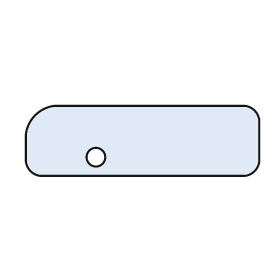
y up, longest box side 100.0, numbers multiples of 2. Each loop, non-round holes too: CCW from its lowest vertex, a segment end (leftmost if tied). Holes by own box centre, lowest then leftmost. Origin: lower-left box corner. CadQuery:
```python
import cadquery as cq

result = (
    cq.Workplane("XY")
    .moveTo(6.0, 0.0)
    .lineTo(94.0, 0.0)
    .threePointArc((98.0, 2.0), (100.0, 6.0))
    .lineTo(100.0, 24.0)
    .threePointArc((98.0, 28.0), (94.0, 30.0))
    .lineTo(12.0, 30.0)
    .threePointArc((4.0, 26.0), (0.0, 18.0))
    .lineTo(0.0, 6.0)
    .threePointArc((2.0, 2.0), (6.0, 0.0))
    .close()
    .moveTo(30.0, 8.0)
    .circle(4.0)
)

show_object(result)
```